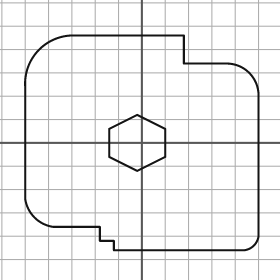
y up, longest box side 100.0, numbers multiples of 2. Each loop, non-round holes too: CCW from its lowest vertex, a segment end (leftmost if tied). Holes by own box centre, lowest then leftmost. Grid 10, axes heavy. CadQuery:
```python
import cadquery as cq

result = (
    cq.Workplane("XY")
    .moveTo(-12.0, -46.0)
    .lineTo(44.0, -46.0)
    .threePointArc((48.0, -44.0), (50.0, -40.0))
    .lineTo(50.0, 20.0)
    .threePointArc((46.0, 30.0), (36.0, 34.0))
    .lineTo(18.0, 34.0)
    .lineTo(18.0, 46.0)
    .lineTo(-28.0, 46.0)
    .threePointArc((-44.0, 40.0), (-50.0, 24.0))
    .lineTo(-50.0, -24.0)
    .threePointArc((-46.0, -32.0), (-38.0, -36.0))
    .lineTo(-18.0, -36.0)
    .lineTo(-18.0, -42.0)
    .lineTo(-12.0, -42.0)
    .close()
    .moveTo(-2.0, -12.0)
    .lineTo(10.0, -6.0)
    .lineTo(10.0, 6.0)
    .lineTo(-2.0, 12.0)
    .lineTo(-14.0, 6.0)
    .lineTo(-14.0, -6.0)
    .close()
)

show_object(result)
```